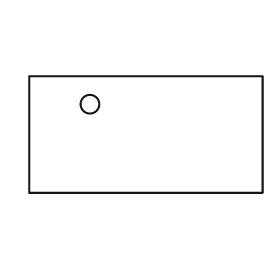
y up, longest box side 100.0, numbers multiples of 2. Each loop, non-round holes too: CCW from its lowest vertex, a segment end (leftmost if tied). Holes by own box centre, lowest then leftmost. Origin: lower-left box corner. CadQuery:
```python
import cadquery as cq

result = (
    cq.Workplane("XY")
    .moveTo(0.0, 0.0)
    .lineTo(100.0, 0.0)
    .lineTo(100.0, 50.0)
    .lineTo(0.0, 50.0)
    .close()
    .moveTo(26.0, 38.0)
    .circle(4.0)
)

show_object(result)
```